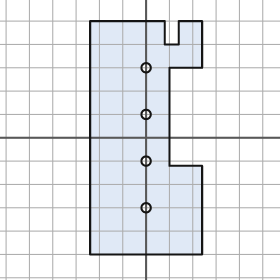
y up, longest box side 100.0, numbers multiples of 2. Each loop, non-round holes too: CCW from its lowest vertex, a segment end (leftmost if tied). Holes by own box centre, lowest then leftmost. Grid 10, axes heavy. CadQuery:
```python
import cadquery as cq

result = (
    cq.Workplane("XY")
    .moveTo(-24.0, -50.0)
    .lineTo(24.0, -50.0)
    .lineTo(24.0, -12.0)
    .lineTo(10.0, -12.0)
    .lineTo(10.0, 30.0)
    .lineTo(24.0, 30.0)
    .lineTo(24.0, 50.0)
    .lineTo(14.0, 50.0)
    .lineTo(14.0, 40.0)
    .lineTo(8.0, 40.0)
    .lineTo(8.0, 50.0)
    .lineTo(-24.0, 50.0)
    .close()
    .moveTo(0.0, -30.0)
    .circle(2.0)
    .moveTo(0.0, -10.0)
    .circle(2.0)
    .moveTo(0.0, 10.0)
    .circle(2.0)
    .moveTo(0.0, 30.0)
    .circle(2.0)
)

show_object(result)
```